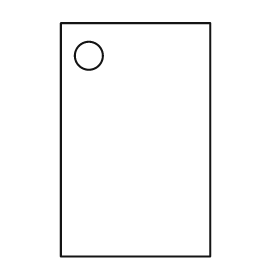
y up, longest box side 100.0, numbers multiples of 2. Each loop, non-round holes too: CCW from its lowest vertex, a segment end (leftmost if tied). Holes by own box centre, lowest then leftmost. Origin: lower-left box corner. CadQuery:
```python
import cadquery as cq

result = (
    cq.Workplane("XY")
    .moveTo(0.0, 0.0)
    .lineTo(64.0, 0.0)
    .lineTo(64.0, 100.0)
    .lineTo(0.0, 100.0)
    .close()
    .moveTo(12.0, 86.0)
    .circle(6.0)
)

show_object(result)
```